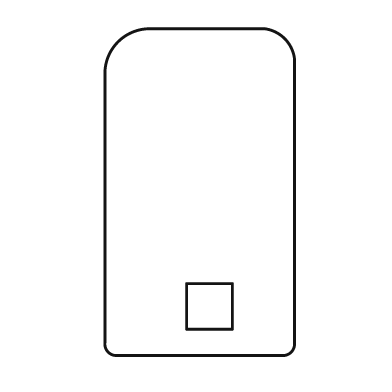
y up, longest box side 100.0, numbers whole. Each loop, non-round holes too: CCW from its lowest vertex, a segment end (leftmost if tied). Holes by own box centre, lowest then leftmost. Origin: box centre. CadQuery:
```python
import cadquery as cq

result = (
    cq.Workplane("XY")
    .moveTo(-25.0, -50.0)
    .lineTo(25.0, -50.0)
    .threePointArc((28.0, -49.0), (29.0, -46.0))
    .lineTo(29.0, 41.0)
    .threePointArc((26.0, 47.0), (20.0, 50.0))
    .lineTo(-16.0, 50.0)
    .threePointArc((-25.0, 46.0), (-29.0, 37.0))
    .lineTo(-29.0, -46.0)
    .threePointArc((-28.0, -49.0), (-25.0, -50.0))
    .close()
    .moveTo(-4.0, -42.0)
    .lineTo(10.0, -42.0)
    .lineTo(10.0, -28.0)
    .lineTo(-4.0, -28.0)
    .close()
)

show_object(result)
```